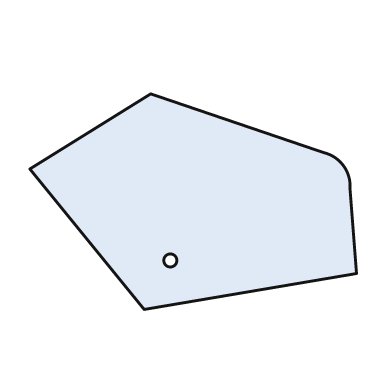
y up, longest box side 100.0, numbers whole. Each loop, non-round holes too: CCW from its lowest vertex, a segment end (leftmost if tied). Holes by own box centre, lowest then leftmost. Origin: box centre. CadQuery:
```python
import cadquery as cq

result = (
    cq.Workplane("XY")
    .moveTo(-15.0, -33.0)
    .lineTo(50.0, -22.0)
    .lineTo(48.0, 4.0)
    .threePointArc((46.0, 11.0), (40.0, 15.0))
    .lineTo(-13.0, 33.0)
    .lineTo(-50.0, 10.0)
    .close()
    .moveTo(-7.0, -18.0)
    .circle(2.0)
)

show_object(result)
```